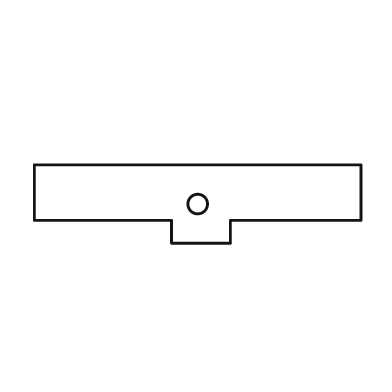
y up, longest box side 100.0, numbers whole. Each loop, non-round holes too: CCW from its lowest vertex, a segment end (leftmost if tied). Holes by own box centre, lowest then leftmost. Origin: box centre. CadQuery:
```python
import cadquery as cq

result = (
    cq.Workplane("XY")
    .moveTo(-8.0, -12.0)
    .lineTo(10.0, -12.0)
    .lineTo(10.0, -5.0)
    .lineTo(50.0, -5.0)
    .lineTo(50.0, 12.0)
    .lineTo(-50.0, 12.0)
    .lineTo(-50.0, -5.0)
    .lineTo(-8.0, -5.0)
    .close()
    .moveTo(0.0, 0.0)
    .circle(3.0)
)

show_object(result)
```